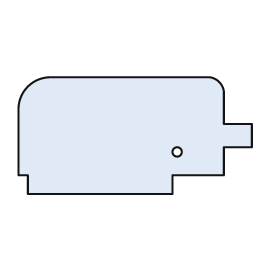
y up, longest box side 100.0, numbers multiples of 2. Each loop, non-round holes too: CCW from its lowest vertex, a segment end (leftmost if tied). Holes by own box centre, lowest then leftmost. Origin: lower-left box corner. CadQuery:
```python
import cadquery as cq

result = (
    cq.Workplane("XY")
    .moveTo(4.0, 0.0)
    .lineTo(66.0, 0.0)
    .lineTo(66.0, 8.0)
    .lineTo(88.0, 8.0)
    .lineTo(88.0, 20.0)
    .lineTo(100.0, 20.0)
    .lineTo(100.0, 30.0)
    .lineTo(88.0, 30.0)
    .lineTo(88.0, 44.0)
    .threePointArc((86.0, 48.0), (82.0, 50.0))
    .lineTo(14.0, 50.0)
    .threePointArc((4.0, 46.0), (0.0, 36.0))
    .lineTo(0.0, 8.0)
    .lineTo(4.0, 8.0)
    .close()
    .moveTo(68.0, 18.0)
    .circle(2.0)
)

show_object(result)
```